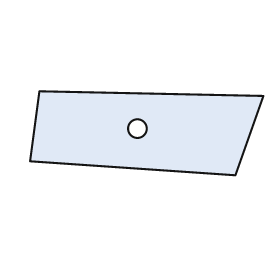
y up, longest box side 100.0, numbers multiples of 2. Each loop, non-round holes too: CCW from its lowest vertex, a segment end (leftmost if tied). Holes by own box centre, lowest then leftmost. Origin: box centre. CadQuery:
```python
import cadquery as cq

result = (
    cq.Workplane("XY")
    .moveTo(38.0, -18.0)
    .lineTo(50.0, 16.0)
    .lineTo(-46.0, 18.0)
    .lineTo(-50.0, -12.0)
    .close()
    .moveTo(-4.0, 2.0)
    .circle(4.0)
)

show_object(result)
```